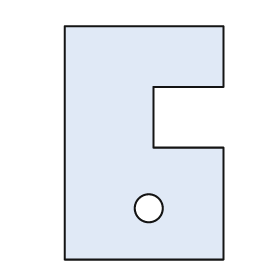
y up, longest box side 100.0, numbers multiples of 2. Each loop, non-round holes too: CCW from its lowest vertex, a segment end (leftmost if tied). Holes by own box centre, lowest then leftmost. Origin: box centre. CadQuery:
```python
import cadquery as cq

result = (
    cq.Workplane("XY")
    .moveTo(-34.0, -50.0)
    .lineTo(34.0, -50.0)
    .lineTo(34.0, -2.0)
    .lineTo(4.0, -2.0)
    .lineTo(4.0, 24.0)
    .lineTo(34.0, 24.0)
    .lineTo(34.0, 50.0)
    .lineTo(-34.0, 50.0)
    .close()
    .moveTo(2.0, -28.0)
    .circle(6.0)
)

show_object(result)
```